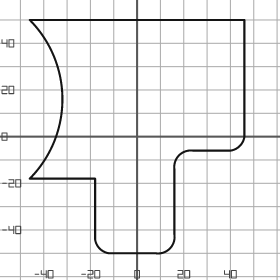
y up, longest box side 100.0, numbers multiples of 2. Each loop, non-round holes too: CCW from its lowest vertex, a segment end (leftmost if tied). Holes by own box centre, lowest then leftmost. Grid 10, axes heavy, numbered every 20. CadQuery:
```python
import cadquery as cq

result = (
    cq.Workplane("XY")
    .moveTo(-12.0, -50.0)
    .lineTo(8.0, -50.0)
    .threePointArc((14.0, -48.0), (16.0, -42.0))
    .lineTo(16.0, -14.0)
    .threePointArc((18.0, -8.0), (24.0, -6.0))
    .lineTo(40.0, -6.0)
    .threePointArc((44.0, -4.0), (46.0, 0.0))
    .lineTo(46.0, 50.0)
    .lineTo(-46.0, 50.0)
    .threePointArc((-32.0, 16.0), (-46.0, -18.0))
    .lineTo(-18.0, -18.0)
    .lineTo(-18.0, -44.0)
    .threePointArc((-16.0, -48.0), (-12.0, -50.0))
    .close()
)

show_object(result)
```